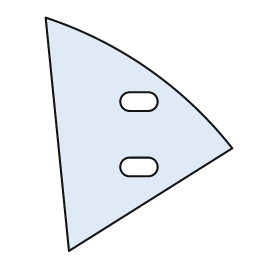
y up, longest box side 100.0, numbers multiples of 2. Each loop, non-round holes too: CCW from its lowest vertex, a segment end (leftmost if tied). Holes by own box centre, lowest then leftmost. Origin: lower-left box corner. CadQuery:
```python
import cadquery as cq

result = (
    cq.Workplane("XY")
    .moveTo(10.0, 0.0)
    .lineTo(80.0, 44.0)
    .threePointArc((44.0, 78.0), (0.0, 100.0))
    .close()
    .moveTo(36.0, 32.0)
    .lineTo(44.0, 32.0)
    .threePointArc((48.0, 36.0), (44.0, 40.0))
    .lineTo(36.0, 40.0)
    .threePointArc((32.0, 36.0), (36.0, 32.0))
    .close()
    .moveTo(36.0, 60.0)
    .lineTo(44.0, 60.0)
    .threePointArc((48.0, 64.0), (44.0, 68.0))
    .lineTo(36.0, 68.0)
    .threePointArc((32.0, 64.0), (36.0, 60.0))
    .close()
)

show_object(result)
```